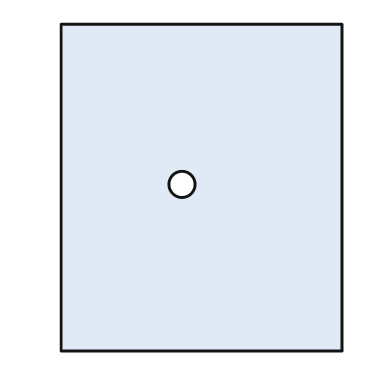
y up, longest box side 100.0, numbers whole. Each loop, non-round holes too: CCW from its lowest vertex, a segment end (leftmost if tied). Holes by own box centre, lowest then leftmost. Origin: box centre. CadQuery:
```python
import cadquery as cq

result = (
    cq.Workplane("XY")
    .moveTo(-43.0, -50.0)
    .lineTo(43.0, -50.0)
    .lineTo(43.0, 50.0)
    .lineTo(-43.0, 50.0)
    .close()
    .moveTo(-6.0, 1.0)
    .circle(4.0)
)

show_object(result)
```